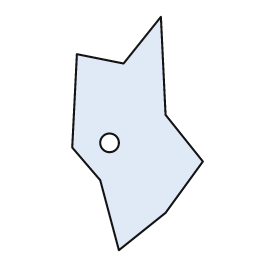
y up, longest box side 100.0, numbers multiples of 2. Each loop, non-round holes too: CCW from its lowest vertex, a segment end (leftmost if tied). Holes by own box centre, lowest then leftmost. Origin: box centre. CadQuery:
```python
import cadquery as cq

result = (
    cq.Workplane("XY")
    .moveTo(-8.0, -50.0)
    .lineTo(12.0, -34.0)
    .lineTo(28.0, -12.0)
    .lineTo(12.0, 8.0)
    .lineTo(10.0, 50.0)
    .lineTo(-6.0, 30.0)
    .lineTo(-26.0, 34.0)
    .lineTo(-28.0, -6.0)
    .lineTo(-16.0, -20.0)
    .close()
    .moveTo(-12.0, -4.0)
    .circle(4.0)
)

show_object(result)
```